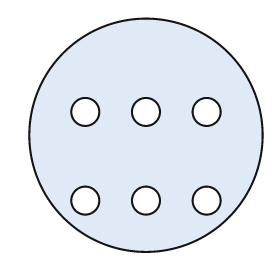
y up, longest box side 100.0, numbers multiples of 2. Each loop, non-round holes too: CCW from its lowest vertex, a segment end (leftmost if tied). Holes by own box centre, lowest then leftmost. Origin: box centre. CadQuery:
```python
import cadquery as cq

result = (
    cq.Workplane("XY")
    .moveTo(0.0, 0.0)
    .circle(50.0)
    .moveTo(-26.0, -28.0)
    .circle(6.0)
    .moveTo(0.0, -28.0)
    .circle(6.0)
    .moveTo(26.0, -28.0)
    .circle(6.0)
    .moveTo(-26.0, 10.0)
    .circle(6.0)
    .moveTo(0.0, 10.0)
    .circle(6.0)
    .moveTo(26.0, 10.0)
    .circle(6.0)
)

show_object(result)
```